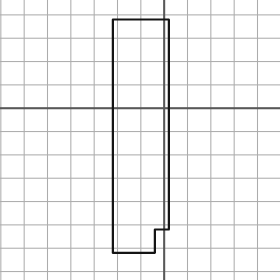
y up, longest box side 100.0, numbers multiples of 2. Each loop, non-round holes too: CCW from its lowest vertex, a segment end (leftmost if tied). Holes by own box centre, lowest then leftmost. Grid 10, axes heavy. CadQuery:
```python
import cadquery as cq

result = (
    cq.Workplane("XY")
    .moveTo(-22.0, -62.0)
    .lineTo(-4.0, -62.0)
    .lineTo(-4.0, -52.0)
    .lineTo(2.0, -52.0)
    .lineTo(2.0, 38.0)
    .lineTo(-22.0, 38.0)
    .close()
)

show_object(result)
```